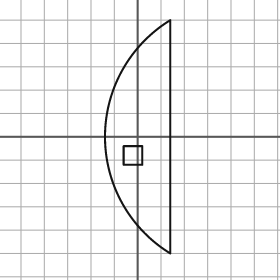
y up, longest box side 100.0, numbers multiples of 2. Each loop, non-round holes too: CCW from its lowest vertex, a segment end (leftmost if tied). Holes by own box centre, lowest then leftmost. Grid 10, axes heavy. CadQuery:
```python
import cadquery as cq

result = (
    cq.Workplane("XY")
    .moveTo(14.0, -50.0)
    .lineTo(14.0, 50.0)
    .threePointArc((-14.0, 0.0), (14.0, -50.0))
    .close()
    .moveTo(-6.0, -12.0)
    .lineTo(2.0, -12.0)
    .lineTo(2.0, -4.0)
    .lineTo(-6.0, -4.0)
    .close()
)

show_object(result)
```